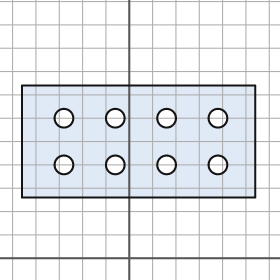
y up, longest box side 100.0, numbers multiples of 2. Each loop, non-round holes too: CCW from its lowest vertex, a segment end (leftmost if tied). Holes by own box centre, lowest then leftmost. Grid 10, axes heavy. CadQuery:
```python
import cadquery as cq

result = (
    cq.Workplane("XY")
    .moveTo(-46.0, 26.0)
    .lineTo(54.0, 26.0)
    .lineTo(54.0, 74.0)
    .lineTo(-46.0, 74.0)
    .close()
    .moveTo(-28.0, 40.0)
    .circle(4.0)
    .moveTo(-6.0, 40.0)
    .circle(4.0)
    .moveTo(16.0, 40.0)
    .circle(4.0)
    .moveTo(38.0, 40.0)
    .circle(4.0)
    .moveTo(-28.0, 60.0)
    .circle(4.0)
    .moveTo(-6.0, 60.0)
    .circle(4.0)
    .moveTo(16.0, 60.0)
    .circle(4.0)
    .moveTo(38.0, 60.0)
    .circle(4.0)
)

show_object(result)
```